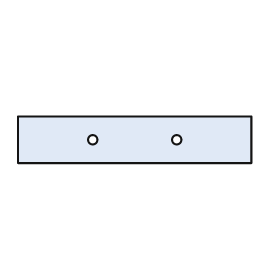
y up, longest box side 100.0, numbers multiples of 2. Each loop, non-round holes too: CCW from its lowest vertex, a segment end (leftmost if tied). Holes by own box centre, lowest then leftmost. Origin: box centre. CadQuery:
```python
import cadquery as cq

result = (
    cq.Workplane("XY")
    .moveTo(-50.0, -10.0)
    .lineTo(50.0, -10.0)
    .lineTo(50.0, 10.0)
    .lineTo(-50.0, 10.0)
    .close()
    .moveTo(-18.0, 0.0)
    .circle(2.0)
    .moveTo(18.0, 0.0)
    .circle(2.0)
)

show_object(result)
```